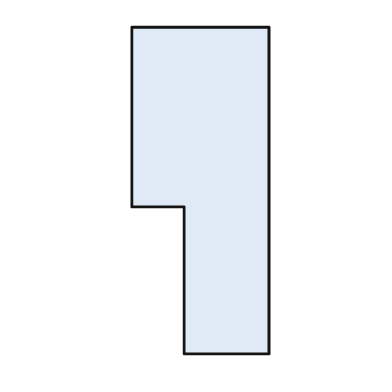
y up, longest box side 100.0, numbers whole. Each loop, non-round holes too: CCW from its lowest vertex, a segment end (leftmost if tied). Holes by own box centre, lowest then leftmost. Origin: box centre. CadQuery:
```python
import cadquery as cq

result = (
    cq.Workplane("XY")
    .moveTo(-5.0, -50.0)
    .lineTo(21.0, -50.0)
    .lineTo(21.0, 50.0)
    .lineTo(-21.0, 50.0)
    .lineTo(-21.0, -5.0)
    .lineTo(-5.0, -5.0)
    .close()
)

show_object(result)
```